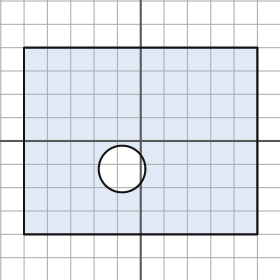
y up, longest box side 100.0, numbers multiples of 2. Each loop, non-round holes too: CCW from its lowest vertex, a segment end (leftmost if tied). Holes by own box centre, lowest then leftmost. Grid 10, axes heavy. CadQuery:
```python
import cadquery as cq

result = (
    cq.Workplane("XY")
    .moveTo(-50.0, -40.0)
    .lineTo(50.0, -40.0)
    .lineTo(50.0, 40.0)
    .lineTo(-50.0, 40.0)
    .close()
    .moveTo(-8.0, -12.0)
    .circle(10.0)
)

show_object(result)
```